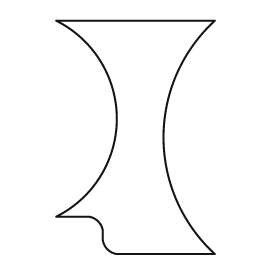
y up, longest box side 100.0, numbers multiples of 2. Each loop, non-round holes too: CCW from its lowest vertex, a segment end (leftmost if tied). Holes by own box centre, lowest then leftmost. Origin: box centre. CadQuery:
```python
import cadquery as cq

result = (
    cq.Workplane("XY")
    .moveTo(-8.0, -50.0)
    .lineTo(34.0, -50.0)
    .threePointArc((12.0, 0.0), (34.0, 50.0))
    .lineTo(-34.0, 50.0)
    .threePointArc((-8.0, 8.0), (-34.0, -34.0))
    .lineTo(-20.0, -34.0)
    .threePointArc((-16.0, -36.0), (-14.0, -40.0))
    .lineTo(-14.0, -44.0)
    .threePointArc((-12.0, -48.0), (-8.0, -50.0))
    .close()
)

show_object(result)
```